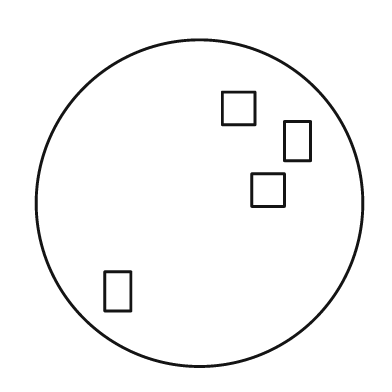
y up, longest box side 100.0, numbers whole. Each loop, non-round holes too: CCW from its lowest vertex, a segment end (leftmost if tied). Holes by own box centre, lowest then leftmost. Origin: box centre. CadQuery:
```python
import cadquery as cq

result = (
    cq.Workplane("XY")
    .moveTo(0.0, 0.0)
    .circle(50.0)
    .moveTo(-29.0, -33.0)
    .lineTo(-21.0, -33.0)
    .lineTo(-21.0, -21.0)
    .lineTo(-29.0, -21.0)
    .close()
    .moveTo(16.0, -1.0)
    .lineTo(26.0, -1.0)
    .lineTo(26.0, 9.0)
    .lineTo(16.0, 9.0)
    .close()
    .moveTo(26.0, 13.0)
    .lineTo(34.0, 13.0)
    .lineTo(34.0, 25.0)
    .lineTo(26.0, 25.0)
    .close()
    .moveTo(7.0, 24.0)
    .lineTo(17.0, 24.0)
    .lineTo(17.0, 34.0)
    .lineTo(7.0, 34.0)
    .close()
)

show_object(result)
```